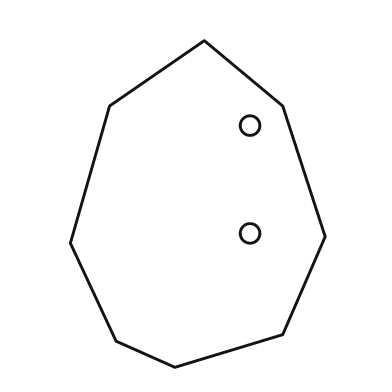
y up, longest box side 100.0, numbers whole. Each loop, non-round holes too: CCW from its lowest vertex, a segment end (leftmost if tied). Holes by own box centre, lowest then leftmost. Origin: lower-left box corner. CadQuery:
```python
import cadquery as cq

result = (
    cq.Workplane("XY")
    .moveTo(32.0, 0.0)
    .lineTo(65.0, 10.0)
    .lineTo(78.0, 40.0)
    .lineTo(65.0, 80.0)
    .lineTo(41.0, 100.0)
    .lineTo(12.0, 80.0)
    .lineTo(0.0, 38.0)
    .lineTo(14.0, 8.0)
    .close()
    .moveTo(55.0, 41.0)
    .circle(3.0)
    .moveTo(55.0, 74.0)
    .circle(3.0)
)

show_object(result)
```